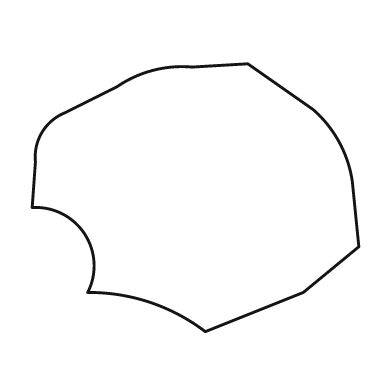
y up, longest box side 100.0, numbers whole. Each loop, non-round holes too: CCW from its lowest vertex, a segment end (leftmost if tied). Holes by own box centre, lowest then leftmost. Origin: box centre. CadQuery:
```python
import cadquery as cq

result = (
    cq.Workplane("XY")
    .moveTo(3.0, -41.0)
    .lineTo(33.0, -29.0)
    .lineTo(50.0, -15.0)
    .lineTo(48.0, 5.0)
    .threePointArc((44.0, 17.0), (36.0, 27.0))
    .lineTo(16.0, 41.0)
    .lineTo(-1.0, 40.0)
    .threePointArc((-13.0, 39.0), (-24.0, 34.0))
    .lineTo(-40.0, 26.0)
    .threePointArc((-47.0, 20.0), (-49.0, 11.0))
    .lineTo(-50.0, -3.0)
    .threePointArc((-34.0, -11.0), (-33.0, -29.0))
    .threePointArc((-14.0, -32.0), (3.0, -41.0))
    .close()
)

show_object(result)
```